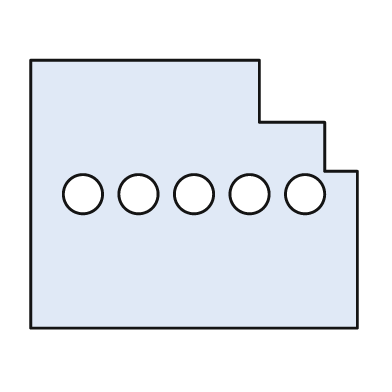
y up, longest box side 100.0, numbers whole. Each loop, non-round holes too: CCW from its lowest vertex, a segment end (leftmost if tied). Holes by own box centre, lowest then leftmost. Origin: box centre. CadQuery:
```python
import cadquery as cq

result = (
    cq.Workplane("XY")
    .moveTo(-50.0, -41.0)
    .lineTo(50.0, -41.0)
    .lineTo(50.0, 7.0)
    .lineTo(40.0, 7.0)
    .lineTo(40.0, 22.0)
    .lineTo(20.0, 22.0)
    .lineTo(20.0, 41.0)
    .lineTo(-50.0, 41.0)
    .close()
    .moveTo(-34.0, 0.0)
    .circle(6.0)
    .moveTo(-17.0, 0.0)
    .circle(6.0)
    .moveTo(0.0, 0.0)
    .circle(6.0)
    .moveTo(17.0, 0.0)
    .circle(6.0)
    .moveTo(34.0, 0.0)
    .circle(6.0)
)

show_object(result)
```